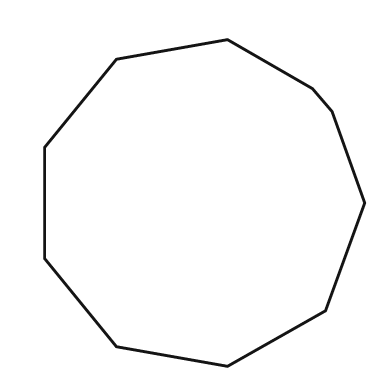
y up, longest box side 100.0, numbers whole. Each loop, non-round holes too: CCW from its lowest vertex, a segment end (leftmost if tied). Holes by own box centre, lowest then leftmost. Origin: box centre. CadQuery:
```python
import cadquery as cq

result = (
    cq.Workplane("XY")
    .moveTo(7.0, -50.0)
    .lineTo(37.0, -33.0)
    .lineTo(49.0, 0.0)
    .lineTo(39.0, 28.0)
    .lineTo(33.0, 35.0)
    .lineTo(7.0, 50.0)
    .lineTo(-27.0, 44.0)
    .lineTo(-49.0, 17.0)
    .lineTo(-49.0, -17.0)
    .lineTo(-27.0, -44.0)
    .close()
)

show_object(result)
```